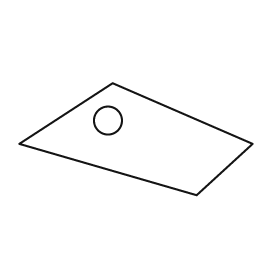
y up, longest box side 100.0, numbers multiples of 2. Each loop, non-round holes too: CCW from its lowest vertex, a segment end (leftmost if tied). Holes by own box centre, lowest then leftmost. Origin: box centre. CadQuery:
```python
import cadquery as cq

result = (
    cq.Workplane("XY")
    .moveTo(26.0, -24.0)
    .lineTo(50.0, -2.0)
    .lineTo(-10.0, 24.0)
    .lineTo(-50.0, -2.0)
    .close()
    .moveTo(-12.0, 8.0)
    .circle(6.0)
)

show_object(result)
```